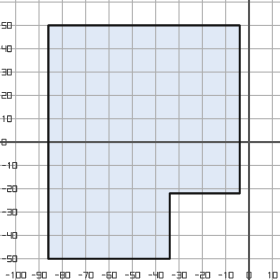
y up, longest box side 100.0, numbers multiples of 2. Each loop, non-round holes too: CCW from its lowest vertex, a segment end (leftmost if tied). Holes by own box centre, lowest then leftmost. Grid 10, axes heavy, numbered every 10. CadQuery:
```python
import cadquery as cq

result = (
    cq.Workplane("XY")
    .moveTo(-86.0, -50.0)
    .lineTo(-34.0, -50.0)
    .lineTo(-34.0, -22.0)
    .lineTo(-4.0, -22.0)
    .lineTo(-4.0, 50.0)
    .lineTo(-86.0, 50.0)
    .close()
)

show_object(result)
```